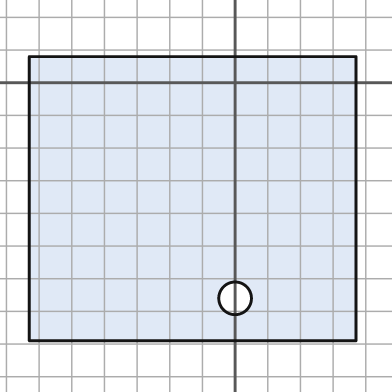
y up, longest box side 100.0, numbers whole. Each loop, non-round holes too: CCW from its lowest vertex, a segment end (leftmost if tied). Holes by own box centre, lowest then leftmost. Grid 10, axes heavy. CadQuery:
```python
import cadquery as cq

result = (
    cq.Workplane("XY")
    .moveTo(-63.0, -79.0)
    .lineTo(37.0, -79.0)
    .lineTo(37.0, 8.0)
    .lineTo(-63.0, 8.0)
    .close()
    .moveTo(0.0, -66.0)
    .circle(5.0)
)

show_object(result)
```